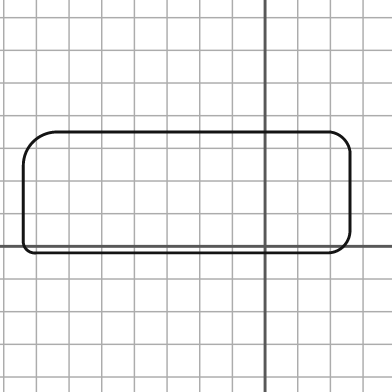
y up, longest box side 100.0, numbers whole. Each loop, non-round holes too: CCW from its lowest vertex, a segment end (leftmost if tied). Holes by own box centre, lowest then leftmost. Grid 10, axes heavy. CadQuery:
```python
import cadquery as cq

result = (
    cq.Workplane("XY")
    .moveTo(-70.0, -2.0)
    .lineTo(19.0, -2.0)
    .threePointArc((24.0, 0.0), (26.0, 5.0))
    .lineTo(26.0, 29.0)
    .threePointArc((24.0, 33.0), (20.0, 35.0))
    .lineTo(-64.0, 35.0)
    .threePointArc((-71.0, 32.0), (-74.0, 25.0))
    .lineTo(-74.0, 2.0)
    .threePointArc((-73.0, -1.0), (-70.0, -2.0))
    .close()
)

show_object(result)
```